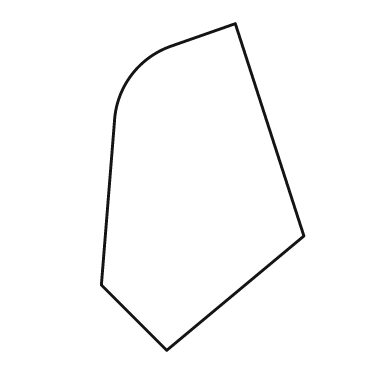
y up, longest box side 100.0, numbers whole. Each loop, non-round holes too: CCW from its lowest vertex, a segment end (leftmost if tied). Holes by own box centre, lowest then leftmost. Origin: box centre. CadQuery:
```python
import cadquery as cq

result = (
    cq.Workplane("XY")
    .moveTo(-11.0, -50.0)
    .lineTo(31.0, -15.0)
    .lineTo(10.0, 50.0)
    .lineTo(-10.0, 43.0)
    .threePointArc((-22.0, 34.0), (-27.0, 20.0))
    .lineTo(-31.0, -30.0)
    .close()
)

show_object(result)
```